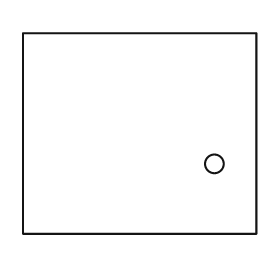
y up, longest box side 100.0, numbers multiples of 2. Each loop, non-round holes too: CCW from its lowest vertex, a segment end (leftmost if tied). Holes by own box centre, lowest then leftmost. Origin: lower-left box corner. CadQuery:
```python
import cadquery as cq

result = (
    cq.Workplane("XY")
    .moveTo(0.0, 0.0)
    .lineTo(100.0, 0.0)
    .lineTo(100.0, 86.0)
    .lineTo(0.0, 86.0)
    .close()
    .moveTo(82.0, 30.0)
    .circle(4.0)
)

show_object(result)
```